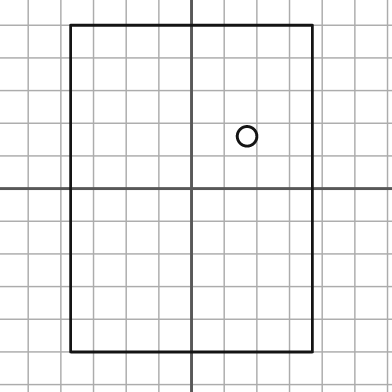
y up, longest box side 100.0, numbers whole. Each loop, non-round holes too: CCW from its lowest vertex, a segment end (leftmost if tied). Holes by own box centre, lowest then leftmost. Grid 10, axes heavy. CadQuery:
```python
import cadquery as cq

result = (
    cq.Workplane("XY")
    .moveTo(-37.0, -50.0)
    .lineTo(37.0, -50.0)
    .lineTo(37.0, 50.0)
    .lineTo(-37.0, 50.0)
    .close()
    .moveTo(17.0, 16.0)
    .circle(3.0)
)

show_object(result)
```